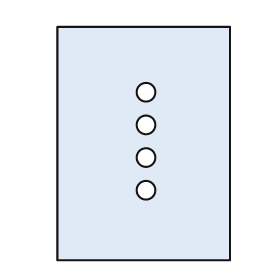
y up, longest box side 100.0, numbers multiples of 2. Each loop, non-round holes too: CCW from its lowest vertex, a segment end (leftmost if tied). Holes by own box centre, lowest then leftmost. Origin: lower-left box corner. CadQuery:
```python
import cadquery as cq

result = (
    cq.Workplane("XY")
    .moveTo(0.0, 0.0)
    .lineTo(74.0, 0.0)
    .lineTo(74.0, 100.0)
    .lineTo(0.0, 100.0)
    .close()
    .moveTo(38.0, 30.0)
    .circle(4.0)
    .moveTo(38.0, 44.0)
    .circle(4.0)
    .moveTo(38.0, 58.0)
    .circle(4.0)
    .moveTo(38.0, 72.0)
    .circle(4.0)
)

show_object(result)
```